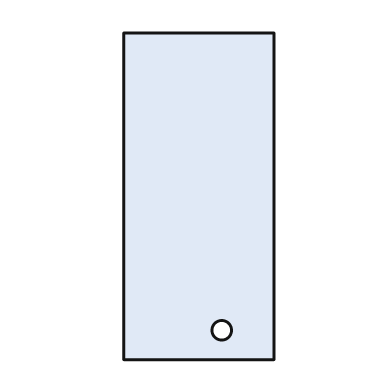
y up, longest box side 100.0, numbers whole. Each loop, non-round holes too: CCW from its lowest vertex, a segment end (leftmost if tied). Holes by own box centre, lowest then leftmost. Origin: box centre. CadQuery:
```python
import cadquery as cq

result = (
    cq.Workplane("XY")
    .moveTo(-23.0, -50.0)
    .lineTo(23.0, -50.0)
    .lineTo(23.0, 50.0)
    .lineTo(-23.0, 50.0)
    .close()
    .moveTo(7.0, -41.0)
    .circle(3.0)
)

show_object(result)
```